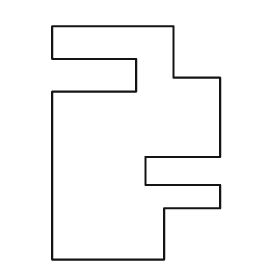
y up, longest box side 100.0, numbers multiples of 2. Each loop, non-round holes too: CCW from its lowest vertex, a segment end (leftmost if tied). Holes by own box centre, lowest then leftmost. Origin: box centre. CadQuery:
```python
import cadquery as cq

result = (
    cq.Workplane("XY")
    .moveTo(-36.0, -50.0)
    .lineTo(12.0, -50.0)
    .lineTo(12.0, -28.0)
    .lineTo(36.0, -28.0)
    .lineTo(36.0, -18.0)
    .lineTo(4.0, -18.0)
    .lineTo(4.0, -6.0)
    .lineTo(36.0, -6.0)
    .lineTo(36.0, 28.0)
    .lineTo(16.0, 28.0)
    .lineTo(16.0, 50.0)
    .lineTo(-36.0, 50.0)
    .lineTo(-36.0, 36.0)
    .lineTo(0.0, 36.0)
    .lineTo(0.0, 22.0)
    .lineTo(-36.0, 22.0)
    .close()
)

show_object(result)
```